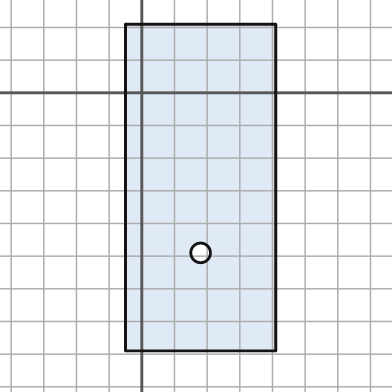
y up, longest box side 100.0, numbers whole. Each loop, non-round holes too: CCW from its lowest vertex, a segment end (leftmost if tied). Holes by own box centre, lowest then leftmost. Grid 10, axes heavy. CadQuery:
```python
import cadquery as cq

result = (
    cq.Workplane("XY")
    .moveTo(-5.0, -79.0)
    .lineTo(41.0, -79.0)
    .lineTo(41.0, 21.0)
    .lineTo(-5.0, 21.0)
    .close()
    .moveTo(18.0, -49.0)
    .circle(3.0)
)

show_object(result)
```